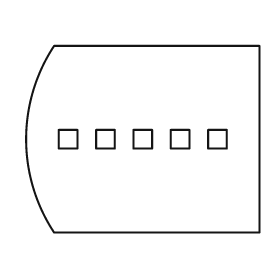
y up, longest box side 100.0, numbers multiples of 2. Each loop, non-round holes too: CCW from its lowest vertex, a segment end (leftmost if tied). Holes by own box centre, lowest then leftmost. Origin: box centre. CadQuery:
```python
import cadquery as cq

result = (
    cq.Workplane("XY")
    .moveTo(-38.0, -40.0)
    .lineTo(50.0, -40.0)
    .lineTo(50.0, 40.0)
    .lineTo(-38.0, 40.0)
    .threePointArc((-50.0, 0.0), (-38.0, -40.0))
    .close()
    .moveTo(-36.0, -4.0)
    .lineTo(-28.0, -4.0)
    .lineTo(-28.0, 4.0)
    .lineTo(-36.0, 4.0)
    .close()
    .moveTo(-20.0, -4.0)
    .lineTo(-12.0, -4.0)
    .lineTo(-12.0, 4.0)
    .lineTo(-20.0, 4.0)
    .close()
    .moveTo(-4.0, -4.0)
    .lineTo(4.0, -4.0)
    .lineTo(4.0, 4.0)
    .lineTo(-4.0, 4.0)
    .close()
    .moveTo(12.0, -4.0)
    .lineTo(20.0, -4.0)
    .lineTo(20.0, 4.0)
    .lineTo(12.0, 4.0)
    .close()
    .moveTo(28.0, -4.0)
    .lineTo(36.0, -4.0)
    .lineTo(36.0, 4.0)
    .lineTo(28.0, 4.0)
    .close()
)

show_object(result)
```